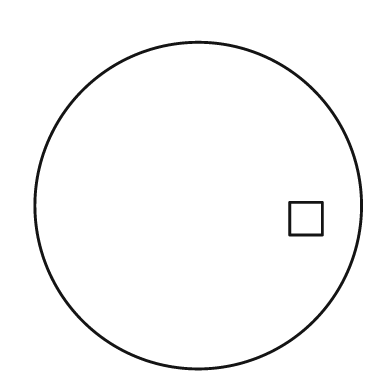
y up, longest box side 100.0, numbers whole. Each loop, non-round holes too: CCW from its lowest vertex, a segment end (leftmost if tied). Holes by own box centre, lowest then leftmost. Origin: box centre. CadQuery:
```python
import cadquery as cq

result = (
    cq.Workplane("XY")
    .moveTo(0.0, 0.0)
    .circle(50.0)
    .moveTo(28.0, -9.0)
    .lineTo(38.0, -9.0)
    .lineTo(38.0, 1.0)
    .lineTo(28.0, 1.0)
    .close()
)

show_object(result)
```